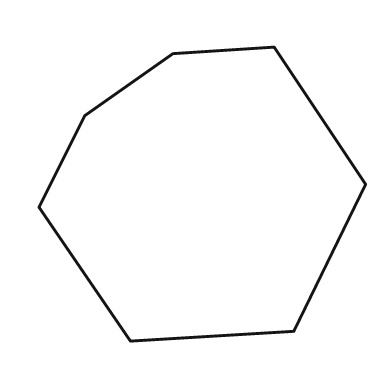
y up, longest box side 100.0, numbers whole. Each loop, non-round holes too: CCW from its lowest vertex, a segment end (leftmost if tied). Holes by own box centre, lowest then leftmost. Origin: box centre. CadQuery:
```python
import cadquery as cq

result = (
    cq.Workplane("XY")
    .moveTo(-22.0, -45.0)
    .lineTo(28.0, -42.0)
    .lineTo(50.0, 3.0)
    .lineTo(22.0, 45.0)
    .lineTo(-9.0, 43.0)
    .lineTo(-36.0, 24.0)
    .lineTo(-50.0, -4.0)
    .close()
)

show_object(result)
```